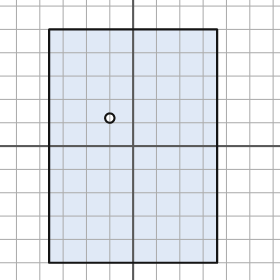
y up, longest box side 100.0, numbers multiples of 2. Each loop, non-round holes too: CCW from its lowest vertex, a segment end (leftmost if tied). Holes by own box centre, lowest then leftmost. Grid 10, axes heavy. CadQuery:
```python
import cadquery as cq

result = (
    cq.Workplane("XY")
    .moveTo(-36.0, -50.0)
    .lineTo(36.0, -50.0)
    .lineTo(36.0, 50.0)
    .lineTo(-36.0, 50.0)
    .close()
    .moveTo(-10.0, 12.0)
    .circle(2.0)
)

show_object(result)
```